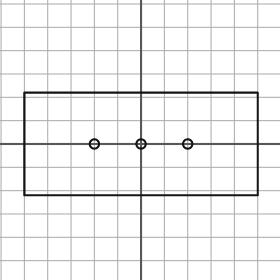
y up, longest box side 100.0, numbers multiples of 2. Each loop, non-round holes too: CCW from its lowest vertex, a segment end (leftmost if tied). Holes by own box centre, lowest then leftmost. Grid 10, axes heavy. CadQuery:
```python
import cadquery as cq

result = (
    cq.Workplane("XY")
    .moveTo(-50.0, -22.0)
    .lineTo(50.0, -22.0)
    .lineTo(50.0, 22.0)
    .lineTo(-50.0, 22.0)
    .close()
    .moveTo(-20.0, 0.0)
    .circle(2.0)
    .moveTo(0.0, 0.0)
    .circle(2.0)
    .moveTo(20.0, 0.0)
    .circle(2.0)
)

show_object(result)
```